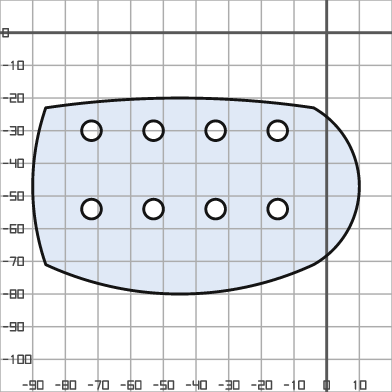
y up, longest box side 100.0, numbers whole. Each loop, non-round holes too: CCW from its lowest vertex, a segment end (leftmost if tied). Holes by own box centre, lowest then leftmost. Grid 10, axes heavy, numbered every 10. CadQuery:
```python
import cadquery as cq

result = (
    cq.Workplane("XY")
    .moveTo(-86.0, -71.0)
    .threePointArc((-45.0, -80.0), (-4.0, -71.0))
    .threePointArc((10.0, -47.0), (-4.0, -23.0))
    .threePointArc((-45.0, -20.0), (-86.0, -23.0))
    .threePointArc((-90.0, -47.0), (-86.0, -71.0))
    .close()
    .moveTo(-72.0, -54.0)
    .circle(3.0)
    .moveTo(-53.0, -54.0)
    .circle(3.0)
    .moveTo(-34.0, -54.0)
    .circle(3.0)
    .moveTo(-15.0, -54.0)
    .circle(3.0)
    .moveTo(-72.0, -30.0)
    .circle(3.0)
    .moveTo(-53.0, -30.0)
    .circle(3.0)
    .moveTo(-34.0, -30.0)
    .circle(3.0)
    .moveTo(-15.0, -30.0)
    .circle(3.0)
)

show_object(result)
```